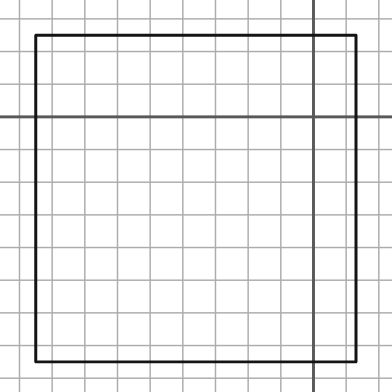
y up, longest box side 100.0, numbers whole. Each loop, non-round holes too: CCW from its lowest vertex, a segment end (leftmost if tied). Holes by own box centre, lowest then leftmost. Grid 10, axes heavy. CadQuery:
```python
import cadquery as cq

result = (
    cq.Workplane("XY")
    .moveTo(-85.0, -75.0)
    .lineTo(13.0, -75.0)
    .lineTo(13.0, 25.0)
    .lineTo(-85.0, 25.0)
    .close()
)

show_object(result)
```